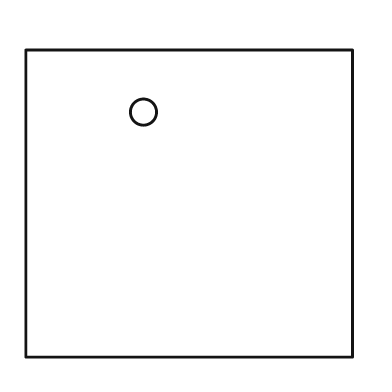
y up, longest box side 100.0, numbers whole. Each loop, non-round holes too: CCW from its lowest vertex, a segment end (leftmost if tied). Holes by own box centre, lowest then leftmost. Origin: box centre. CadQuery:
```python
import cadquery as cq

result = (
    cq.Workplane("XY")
    .moveTo(-50.0, -47.0)
    .lineTo(50.0, -47.0)
    .lineTo(50.0, 47.0)
    .lineTo(-50.0, 47.0)
    .close()
    .moveTo(-14.0, 28.0)
    .circle(4.0)
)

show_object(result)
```